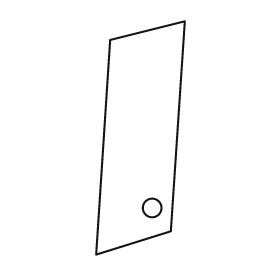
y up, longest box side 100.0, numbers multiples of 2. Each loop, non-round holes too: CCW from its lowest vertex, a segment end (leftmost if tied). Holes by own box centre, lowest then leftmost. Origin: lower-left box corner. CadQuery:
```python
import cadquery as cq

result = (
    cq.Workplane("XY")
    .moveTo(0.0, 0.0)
    .lineTo(32.0, 10.0)
    .lineTo(38.0, 100.0)
    .lineTo(6.0, 92.0)
    .close()
    .moveTo(24.0, 20.0)
    .circle(4.0)
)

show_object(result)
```